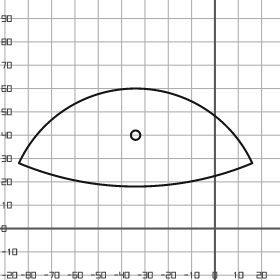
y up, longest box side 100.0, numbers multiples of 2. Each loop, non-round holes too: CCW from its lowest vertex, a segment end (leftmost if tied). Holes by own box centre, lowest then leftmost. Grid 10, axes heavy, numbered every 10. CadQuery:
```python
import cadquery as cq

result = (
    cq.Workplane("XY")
    .moveTo(-84.0, 28.0)
    .threePointArc((-34.0, 18.0), (16.0, 28.0))
    .threePointArc((-34.0, 60.0), (-84.0, 28.0))
    .close()
    .moveTo(-34.0, 40.0)
    .circle(2.0)
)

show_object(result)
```